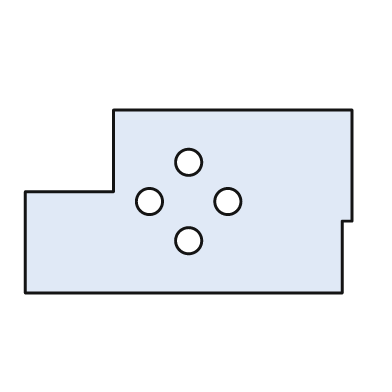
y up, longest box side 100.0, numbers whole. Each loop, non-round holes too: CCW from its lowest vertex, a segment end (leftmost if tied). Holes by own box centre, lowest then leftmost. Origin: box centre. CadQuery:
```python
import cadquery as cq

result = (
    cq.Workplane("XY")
    .moveTo(-50.0, -28.0)
    .lineTo(47.0, -28.0)
    .lineTo(47.0, -6.0)
    .lineTo(50.0, -6.0)
    .lineTo(50.0, 28.0)
    .lineTo(-23.0, 28.0)
    .lineTo(-23.0, 3.0)
    .lineTo(-50.0, 3.0)
    .close()
    .moveTo(0.0, -12.0)
    .circle(4.0)
    .moveTo(-12.0, 0.0)
    .circle(4.0)
    .moveTo(12.0, 0.0)
    .circle(4.0)
    .moveTo(0.0, 12.0)
    .circle(4.0)
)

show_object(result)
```